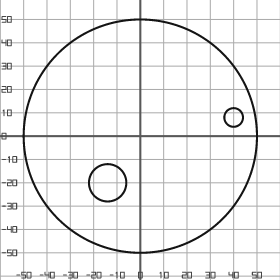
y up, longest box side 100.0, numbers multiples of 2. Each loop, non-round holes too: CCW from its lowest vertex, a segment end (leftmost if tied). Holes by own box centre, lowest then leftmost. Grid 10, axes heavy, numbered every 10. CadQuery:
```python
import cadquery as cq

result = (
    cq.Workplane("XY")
    .moveTo(0.0, 0.0)
    .circle(50.0)
    .moveTo(-14.0, -20.0)
    .circle(8.0)
    .moveTo(40.0, 8.0)
    .circle(4.0)
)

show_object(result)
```